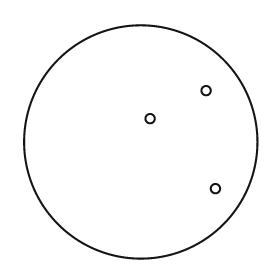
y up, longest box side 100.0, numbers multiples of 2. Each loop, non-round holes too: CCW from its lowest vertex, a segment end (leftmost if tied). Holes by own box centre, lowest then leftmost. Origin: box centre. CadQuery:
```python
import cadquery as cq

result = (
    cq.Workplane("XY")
    .moveTo(0.0, 0.0)
    .circle(50.0)
    .moveTo(32.0, -20.0)
    .circle(2.0)
    .moveTo(4.0, 10.0)
    .circle(2.0)
    .moveTo(28.0, 22.0)
    .circle(2.0)
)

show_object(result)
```